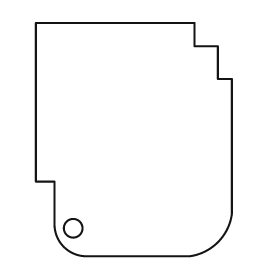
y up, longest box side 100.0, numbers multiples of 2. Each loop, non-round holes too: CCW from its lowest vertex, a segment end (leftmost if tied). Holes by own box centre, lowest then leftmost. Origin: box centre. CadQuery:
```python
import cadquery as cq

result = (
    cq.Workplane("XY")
    .moveTo(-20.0, -50.0)
    .lineTo(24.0, -50.0)
    .threePointArc((36.0, -44.0), (42.0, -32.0))
    .lineTo(42.0, 26.0)
    .lineTo(36.0, 26.0)
    .lineTo(36.0, 40.0)
    .lineTo(26.0, 40.0)
    .lineTo(26.0, 50.0)
    .lineTo(-42.0, 50.0)
    .lineTo(-42.0, -18.0)
    .lineTo(-34.0, -18.0)
    .lineTo(-34.0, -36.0)
    .threePointArc((-30.0, -46.0), (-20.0, -50.0))
    .close()
    .moveTo(-26.0, -38.0)
    .circle(4.0)
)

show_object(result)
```